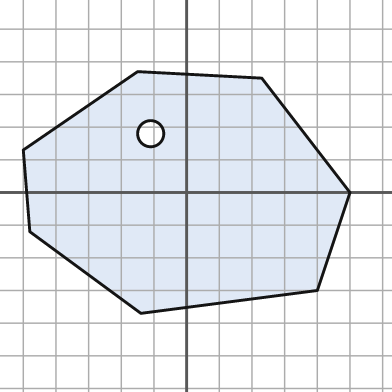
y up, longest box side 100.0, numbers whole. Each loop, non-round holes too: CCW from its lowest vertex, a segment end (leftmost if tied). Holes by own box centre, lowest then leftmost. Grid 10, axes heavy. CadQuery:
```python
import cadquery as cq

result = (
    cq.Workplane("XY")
    .moveTo(-14.0, -37.0)
    .lineTo(40.0, -30.0)
    .lineTo(50.0, 0.0)
    .lineTo(23.0, 35.0)
    .lineTo(-15.0, 37.0)
    .lineTo(-50.0, 13.0)
    .lineTo(-48.0, -12.0)
    .close()
    .moveTo(-11.0, 18.0)
    .circle(4.0)
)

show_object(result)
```